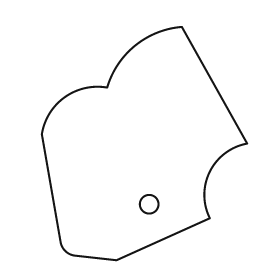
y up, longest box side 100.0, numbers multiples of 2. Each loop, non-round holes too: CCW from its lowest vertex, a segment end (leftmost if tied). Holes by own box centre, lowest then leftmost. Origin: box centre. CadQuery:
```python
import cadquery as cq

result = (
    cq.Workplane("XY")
    .moveTo(-12.0, -50.0)
    .lineTo(28.0, -32.0)
    .threePointArc((28.0, -12.0), (44.0, 0.0))
    .lineTo(16.0, 50.0)
    .threePointArc((-4.0, 42.0), (-16.0, 24.0))
    .threePointArc((-34.0, 20.0), (-44.0, 4.0))
    .lineTo(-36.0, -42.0)
    .threePointArc((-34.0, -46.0), (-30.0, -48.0))
    .close()
    .moveTo(2.0, -26.0)
    .circle(4.0)
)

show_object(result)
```